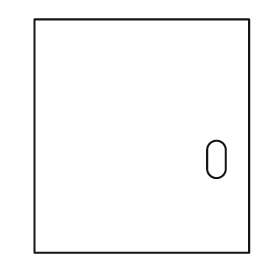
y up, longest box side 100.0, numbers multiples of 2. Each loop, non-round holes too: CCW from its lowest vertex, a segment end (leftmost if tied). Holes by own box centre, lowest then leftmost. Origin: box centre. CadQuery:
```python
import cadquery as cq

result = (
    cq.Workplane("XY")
    .moveTo(-46.0, -50.0)
    .lineTo(46.0, -50.0)
    .lineTo(46.0, 50.0)
    .lineTo(-46.0, 50.0)
    .close()
    .moveTo(28.0, -14.0)
    .threePointArc((32.0, -18.0), (36.0, -14.0))
    .lineTo(36.0, -6.0)
    .threePointArc((32.0, -2.0), (28.0, -6.0))
    .close()
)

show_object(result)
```